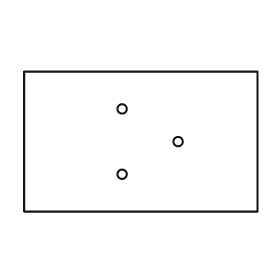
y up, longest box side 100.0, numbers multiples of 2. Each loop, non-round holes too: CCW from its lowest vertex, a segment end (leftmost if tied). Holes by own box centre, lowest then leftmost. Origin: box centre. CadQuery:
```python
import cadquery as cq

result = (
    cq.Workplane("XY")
    .moveTo(-50.0, -30.0)
    .lineTo(50.0, -30.0)
    .lineTo(50.0, 30.0)
    .lineTo(-50.0, 30.0)
    .close()
    .moveTo(-8.0, -14.0)
    .circle(2.0)
    .moveTo(16.0, 0.0)
    .circle(2.0)
    .moveTo(-8.0, 14.0)
    .circle(2.0)
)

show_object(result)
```